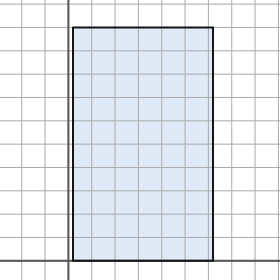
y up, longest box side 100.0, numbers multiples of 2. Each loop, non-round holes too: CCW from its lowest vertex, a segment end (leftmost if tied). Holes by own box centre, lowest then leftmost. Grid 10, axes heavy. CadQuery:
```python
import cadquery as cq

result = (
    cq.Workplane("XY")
    .moveTo(2.0, 0.0)
    .lineTo(62.0, 0.0)
    .lineTo(62.0, 100.0)
    .lineTo(2.0, 100.0)
    .close()
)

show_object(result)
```